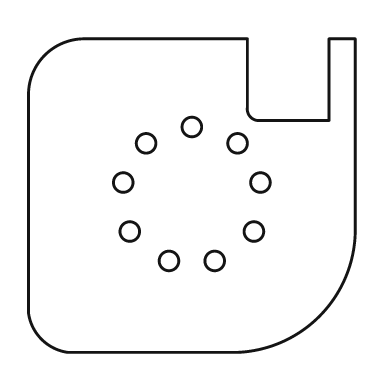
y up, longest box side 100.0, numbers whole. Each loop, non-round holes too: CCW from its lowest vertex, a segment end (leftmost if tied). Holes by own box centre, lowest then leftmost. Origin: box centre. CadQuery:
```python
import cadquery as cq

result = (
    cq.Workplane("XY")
    .moveTo(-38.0, -48.0)
    .lineTo(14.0, -48.0)
    .threePointArc((39.0, -37.0), (50.0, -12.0))
    .lineTo(50.0, 48.0)
    .lineTo(42.0, 48.0)
    .lineTo(42.0, 23.0)
    .lineTo(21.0, 23.0)
    .threePointArc((18.0, 24.0), (17.0, 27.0))
    .lineTo(17.0, 48.0)
    .lineTo(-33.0, 48.0)
    .threePointArc((-45.0, 43.0), (-50.0, 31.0))
    .lineTo(-50.0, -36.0)
    .threePointArc((-46.0, -44.0), (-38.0, -48.0))
    .close()
    .moveTo(-7.0, -20.0)
    .circle(3.0)
    .moveTo(7.0, -20.0)
    .circle(3.0)
    .moveTo(-19.0, -11.0)
    .circle(3.0)
    .moveTo(19.0, -11.0)
    .circle(3.0)
    .moveTo(-21.0, 4.0)
    .circle(3.0)
    .moveTo(21.0, 4.0)
    .circle(3.0)
    .moveTo(-14.0, 16.0)
    .circle(3.0)
    .moveTo(14.0, 16.0)
    .circle(3.0)
    .moveTo(0.0, 21.0)
    .circle(3.0)
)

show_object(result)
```